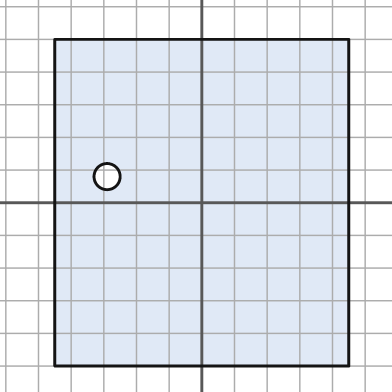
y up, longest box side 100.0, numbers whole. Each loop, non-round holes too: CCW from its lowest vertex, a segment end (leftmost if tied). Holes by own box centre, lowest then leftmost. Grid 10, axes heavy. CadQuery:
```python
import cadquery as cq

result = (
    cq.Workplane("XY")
    .moveTo(-45.0, -50.0)
    .lineTo(45.0, -50.0)
    .lineTo(45.0, 50.0)
    .lineTo(-45.0, 50.0)
    .close()
    .moveTo(-29.0, 8.0)
    .circle(4.0)
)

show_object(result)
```